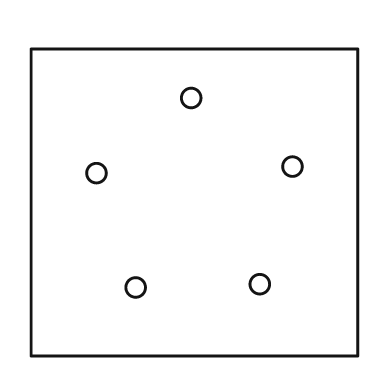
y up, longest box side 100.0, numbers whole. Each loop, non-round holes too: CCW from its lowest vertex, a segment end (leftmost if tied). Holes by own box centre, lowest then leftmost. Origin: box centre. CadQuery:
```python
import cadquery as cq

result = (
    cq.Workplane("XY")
    .moveTo(-50.0, -47.0)
    .lineTo(50.0, -47.0)
    .lineTo(50.0, 47.0)
    .lineTo(-50.0, 47.0)
    .close()
    .moveTo(-18.0, -26.0)
    .circle(3.0)
    .moveTo(20.0, -25.0)
    .circle(3.0)
    .moveTo(-30.0, 9.0)
    .circle(3.0)
    .moveTo(30.0, 11.0)
    .circle(3.0)
    .moveTo(-1.0, 32.0)
    .circle(3.0)
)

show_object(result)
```